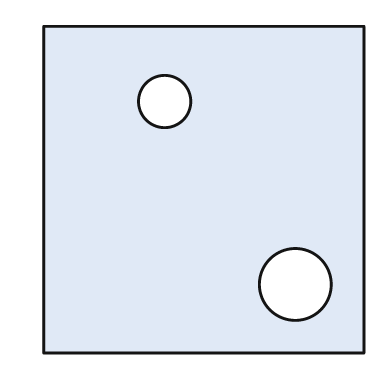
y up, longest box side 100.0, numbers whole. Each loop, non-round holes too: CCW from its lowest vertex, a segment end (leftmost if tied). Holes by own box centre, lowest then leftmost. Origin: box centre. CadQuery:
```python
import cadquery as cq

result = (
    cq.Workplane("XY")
    .moveTo(-49.0, -50.0)
    .lineTo(49.0, -50.0)
    .lineTo(49.0, 50.0)
    .lineTo(-49.0, 50.0)
    .close()
    .moveTo(28.0, -29.0)
    .circle(11.0)
    .moveTo(-12.0, 27.0)
    .circle(8.0)
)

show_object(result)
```